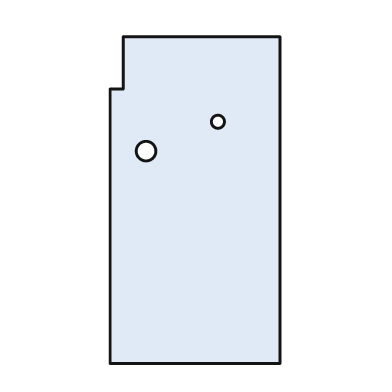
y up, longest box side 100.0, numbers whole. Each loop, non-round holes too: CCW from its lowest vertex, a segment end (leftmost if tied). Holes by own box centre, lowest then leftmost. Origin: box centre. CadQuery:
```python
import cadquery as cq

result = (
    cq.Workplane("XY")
    .moveTo(-26.0, -50.0)
    .lineTo(26.0, -50.0)
    .lineTo(26.0, 50.0)
    .lineTo(-22.0, 50.0)
    .lineTo(-22.0, 34.0)
    .lineTo(-26.0, 34.0)
    .close()
    .moveTo(-15.0, 15.0)
    .circle(3.0)
    .moveTo(7.0, 24.0)
    .circle(2.0)
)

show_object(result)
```